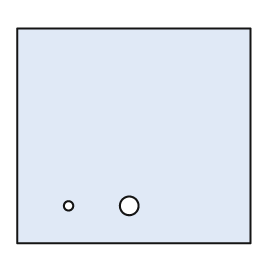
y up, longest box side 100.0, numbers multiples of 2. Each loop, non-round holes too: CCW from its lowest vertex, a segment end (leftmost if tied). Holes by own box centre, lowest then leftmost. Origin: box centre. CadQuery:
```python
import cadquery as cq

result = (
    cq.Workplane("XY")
    .moveTo(-50.0, -46.0)
    .lineTo(50.0, -46.0)
    .lineTo(50.0, 46.0)
    .lineTo(-50.0, 46.0)
    .close()
    .moveTo(-28.0, -30.0)
    .circle(2.0)
    .moveTo(-2.0, -30.0)
    .circle(4.0)
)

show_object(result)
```